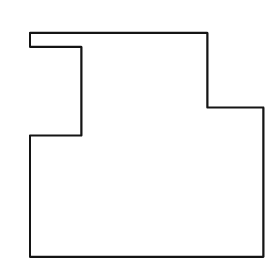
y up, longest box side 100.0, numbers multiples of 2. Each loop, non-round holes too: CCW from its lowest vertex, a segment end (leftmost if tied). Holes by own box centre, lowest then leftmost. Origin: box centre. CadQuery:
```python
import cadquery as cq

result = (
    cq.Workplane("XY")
    .moveTo(-50.0, -48.0)
    .lineTo(50.0, -48.0)
    .lineTo(50.0, 16.0)
    .lineTo(26.0, 16.0)
    .lineTo(26.0, 48.0)
    .lineTo(-50.0, 48.0)
    .lineTo(-50.0, 42.0)
    .lineTo(-28.0, 42.0)
    .lineTo(-28.0, 4.0)
    .lineTo(-50.0, 4.0)
    .close()
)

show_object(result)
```